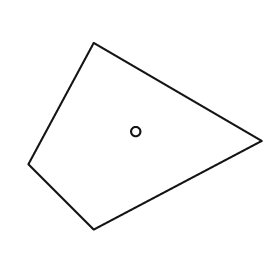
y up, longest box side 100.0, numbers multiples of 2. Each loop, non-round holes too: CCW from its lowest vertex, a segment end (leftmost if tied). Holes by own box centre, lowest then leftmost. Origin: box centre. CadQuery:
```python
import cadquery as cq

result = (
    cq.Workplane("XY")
    .moveTo(-22.0, -40.0)
    .lineTo(50.0, -2.0)
    .lineTo(-22.0, 40.0)
    .lineTo(-50.0, -12.0)
    .close()
    .moveTo(-4.0, 2.0)
    .circle(2.0)
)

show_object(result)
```